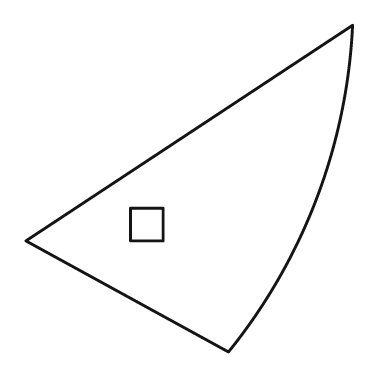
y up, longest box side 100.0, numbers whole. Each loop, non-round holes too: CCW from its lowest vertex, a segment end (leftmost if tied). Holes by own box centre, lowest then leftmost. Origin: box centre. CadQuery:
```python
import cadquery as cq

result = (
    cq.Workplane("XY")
    .moveTo(12.0, -50.0)
    .threePointArc((39.0, -3.0), (50.0, 50.0))
    .lineTo(-50.0, -16.0)
    .close()
    .moveTo(-18.0, -16.0)
    .lineTo(-8.0, -16.0)
    .lineTo(-8.0, -6.0)
    .lineTo(-18.0, -6.0)
    .close()
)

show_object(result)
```